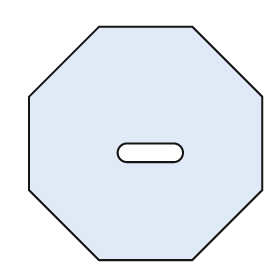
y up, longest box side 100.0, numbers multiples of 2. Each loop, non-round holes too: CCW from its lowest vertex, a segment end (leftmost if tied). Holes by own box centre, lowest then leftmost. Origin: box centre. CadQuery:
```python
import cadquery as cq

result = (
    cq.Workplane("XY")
    .moveTo(-20.0, -50.0)
    .lineTo(20.0, -50.0)
    .lineTo(50.0, -20.0)
    .lineTo(50.0, 20.0)
    .lineTo(20.0, 50.0)
    .lineTo(-20.0, 50.0)
    .lineTo(-50.0, 20.0)
    .lineTo(-50.0, -20.0)
    .close()
    .moveTo(-8.0, -8.0)
    .lineTo(12.0, -8.0)
    .threePointArc((16.0, -4.0), (12.0, 0.0))
    .lineTo(-8.0, 0.0)
    .threePointArc((-12.0, -4.0), (-8.0, -8.0))
    .close()
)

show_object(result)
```